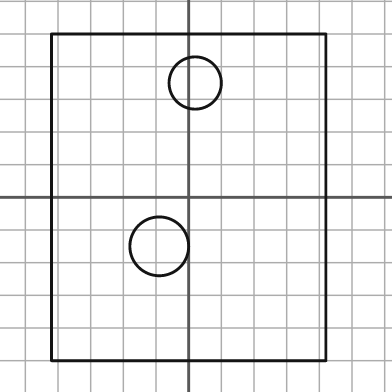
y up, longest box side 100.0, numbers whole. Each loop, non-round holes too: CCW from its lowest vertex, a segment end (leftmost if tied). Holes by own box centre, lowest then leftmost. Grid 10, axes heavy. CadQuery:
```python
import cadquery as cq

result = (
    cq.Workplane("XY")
    .moveTo(-42.0, -50.0)
    .lineTo(42.0, -50.0)
    .lineTo(42.0, 50.0)
    .lineTo(-42.0, 50.0)
    .close()
    .moveTo(-9.0, -15.0)
    .circle(9.0)
    .moveTo(2.0, 35.0)
    .circle(8.0)
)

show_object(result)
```